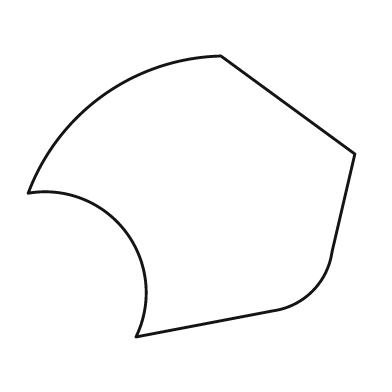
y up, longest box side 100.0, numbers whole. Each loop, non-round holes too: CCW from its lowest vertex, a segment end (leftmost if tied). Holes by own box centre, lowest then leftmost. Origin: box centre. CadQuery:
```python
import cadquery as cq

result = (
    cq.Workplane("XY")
    .moveTo(-17.0, -43.0)
    .lineTo(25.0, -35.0)
    .threePointArc((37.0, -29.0), (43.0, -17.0))
    .lineTo(50.0, 13.0)
    .lineTo(9.0, 43.0)
    .threePointArc((-27.0, 31.0), (-50.0, 1.0))
    .threePointArc((-20.0, -11.0), (-17.0, -43.0))
    .close()
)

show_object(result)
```